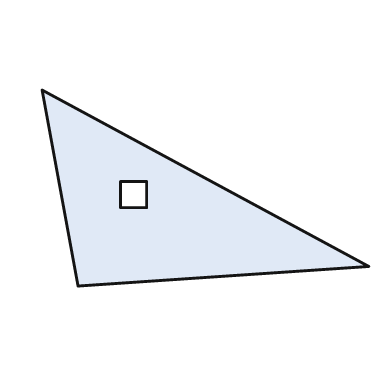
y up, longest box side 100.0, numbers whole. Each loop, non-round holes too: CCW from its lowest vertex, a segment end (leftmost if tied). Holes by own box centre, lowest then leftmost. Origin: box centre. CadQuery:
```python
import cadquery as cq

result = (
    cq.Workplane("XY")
    .moveTo(-39.0, -30.0)
    .lineTo(50.0, -24.0)
    .lineTo(-50.0, 30.0)
    .close()
    .moveTo(-26.0, -6.0)
    .lineTo(-18.0, -6.0)
    .lineTo(-18.0, 2.0)
    .lineTo(-26.0, 2.0)
    .close()
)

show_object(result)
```